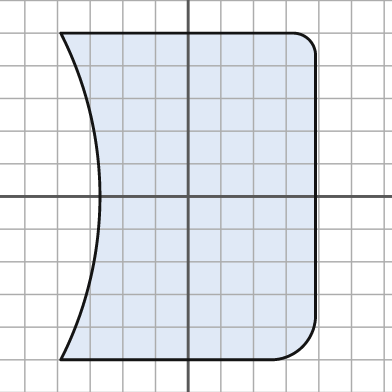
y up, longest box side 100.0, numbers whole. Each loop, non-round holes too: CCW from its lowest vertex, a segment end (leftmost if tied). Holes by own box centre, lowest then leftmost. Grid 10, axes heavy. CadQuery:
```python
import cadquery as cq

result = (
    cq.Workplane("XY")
    .moveTo(-39.0, -50.0)
    .lineTo(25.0, -50.0)
    .threePointArc((35.0, -46.0), (39.0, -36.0))
    .lineTo(39.0, 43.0)
    .threePointArc((37.0, 48.0), (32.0, 50.0))
    .lineTo(-39.0, 50.0)
    .threePointArc((-27.0, 0.0), (-39.0, -50.0))
    .close()
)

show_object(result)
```